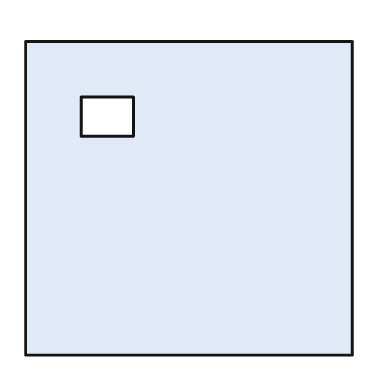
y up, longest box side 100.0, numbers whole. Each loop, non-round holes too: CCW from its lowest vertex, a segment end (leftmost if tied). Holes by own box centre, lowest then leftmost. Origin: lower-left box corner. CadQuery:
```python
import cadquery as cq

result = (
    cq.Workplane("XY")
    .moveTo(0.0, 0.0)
    .lineTo(100.0, 0.0)
    .lineTo(100.0, 96.0)
    .lineTo(0.0, 96.0)
    .close()
    .moveTo(17.0, 67.0)
    .lineTo(33.0, 67.0)
    .lineTo(33.0, 79.0)
    .lineTo(17.0, 79.0)
    .close()
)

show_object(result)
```